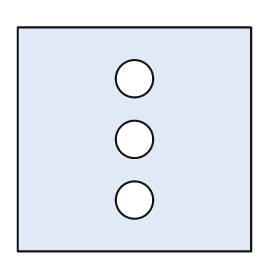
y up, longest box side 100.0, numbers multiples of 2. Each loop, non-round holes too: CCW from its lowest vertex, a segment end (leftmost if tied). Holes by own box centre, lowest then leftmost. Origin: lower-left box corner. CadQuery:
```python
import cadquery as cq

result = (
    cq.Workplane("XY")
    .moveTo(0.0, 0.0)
    .lineTo(100.0, 0.0)
    .lineTo(100.0, 96.0)
    .lineTo(0.0, 96.0)
    .close()
    .moveTo(50.0, 22.0)
    .circle(8.0)
    .moveTo(50.0, 48.0)
    .circle(8.0)
    .moveTo(50.0, 74.0)
    .circle(8.0)
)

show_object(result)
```